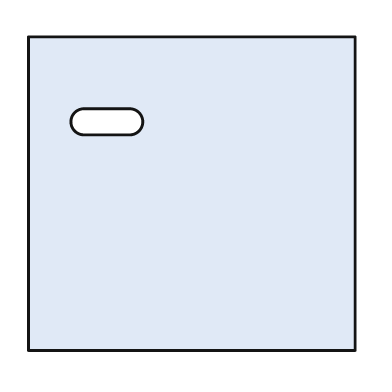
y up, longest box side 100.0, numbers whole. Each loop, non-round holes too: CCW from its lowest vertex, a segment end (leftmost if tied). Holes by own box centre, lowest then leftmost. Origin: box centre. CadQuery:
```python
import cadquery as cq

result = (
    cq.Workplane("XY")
    .moveTo(-50.0, -48.0)
    .lineTo(50.0, -48.0)
    .lineTo(50.0, 48.0)
    .lineTo(-50.0, 48.0)
    .close()
    .moveTo(-33.0, 18.0)
    .lineTo(-19.0, 18.0)
    .threePointArc((-15.0, 22.0), (-19.0, 26.0))
    .lineTo(-33.0, 26.0)
    .threePointArc((-37.0, 22.0), (-33.0, 18.0))
    .close()
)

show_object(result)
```